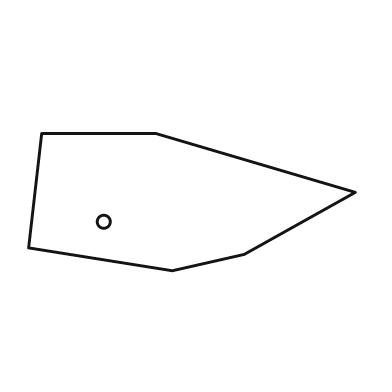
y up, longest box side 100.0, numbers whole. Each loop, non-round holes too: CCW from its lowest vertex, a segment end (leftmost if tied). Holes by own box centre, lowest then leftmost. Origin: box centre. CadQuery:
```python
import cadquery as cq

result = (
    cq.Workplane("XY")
    .moveTo(-6.0, -21.0)
    .lineTo(16.0, -16.0)
    .lineTo(50.0, 3.0)
    .lineTo(-11.0, 21.0)
    .lineTo(-46.0, 21.0)
    .lineTo(-50.0, -14.0)
    .close()
    .moveTo(-27.0, -6.0)
    .circle(2.0)
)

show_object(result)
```